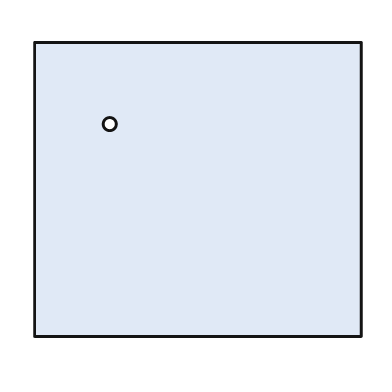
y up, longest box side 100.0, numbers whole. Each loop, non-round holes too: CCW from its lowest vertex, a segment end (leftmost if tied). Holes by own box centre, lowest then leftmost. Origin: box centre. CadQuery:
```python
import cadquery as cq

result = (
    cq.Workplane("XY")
    .moveTo(-50.0, -45.0)
    .lineTo(50.0, -45.0)
    .lineTo(50.0, 45.0)
    .lineTo(-50.0, 45.0)
    .close()
    .moveTo(-27.0, 20.0)
    .circle(2.0)
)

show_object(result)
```